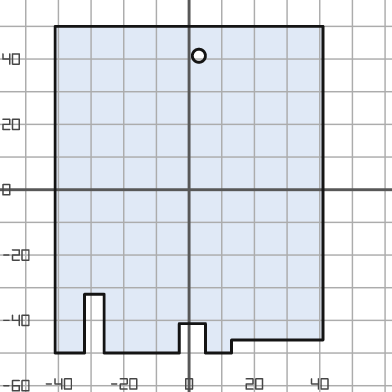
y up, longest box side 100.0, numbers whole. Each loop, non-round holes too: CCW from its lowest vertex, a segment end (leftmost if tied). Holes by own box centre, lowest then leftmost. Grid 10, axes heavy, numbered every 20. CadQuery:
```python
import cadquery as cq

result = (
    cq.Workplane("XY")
    .moveTo(-41.0, -50.0)
    .lineTo(-32.0, -50.0)
    .lineTo(-32.0, -32.0)
    .lineTo(-26.0, -32.0)
    .lineTo(-26.0, -50.0)
    .lineTo(-3.0, -50.0)
    .lineTo(-3.0, -41.0)
    .lineTo(5.0, -41.0)
    .lineTo(5.0, -50.0)
    .lineTo(13.0, -50.0)
    .lineTo(13.0, -46.0)
    .lineTo(41.0, -46.0)
    .lineTo(41.0, 50.0)
    .lineTo(-41.0, 50.0)
    .close()
    .moveTo(3.0, 41.0)
    .circle(2.0)
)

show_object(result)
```